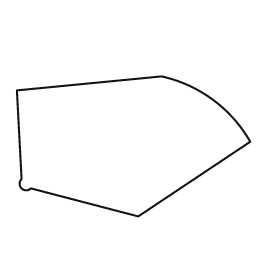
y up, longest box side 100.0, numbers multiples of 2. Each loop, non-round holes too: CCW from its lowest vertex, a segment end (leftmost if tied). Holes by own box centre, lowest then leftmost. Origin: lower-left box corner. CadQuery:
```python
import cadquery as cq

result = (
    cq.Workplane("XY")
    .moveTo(52.0, 0.0)
    .lineTo(100.0, 32.0)
    .threePointArc((84.0, 50.0), (62.0, 60.0))
    .lineTo(0.0, 54.0)
    .lineTo(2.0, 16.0)
    .threePointArc((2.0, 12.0), (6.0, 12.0))
    .close()
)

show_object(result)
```